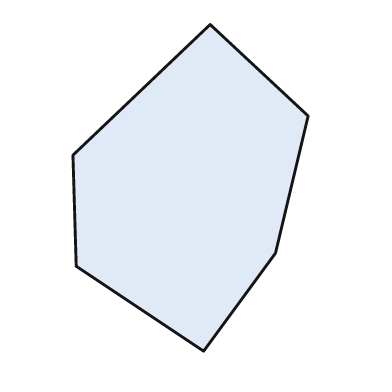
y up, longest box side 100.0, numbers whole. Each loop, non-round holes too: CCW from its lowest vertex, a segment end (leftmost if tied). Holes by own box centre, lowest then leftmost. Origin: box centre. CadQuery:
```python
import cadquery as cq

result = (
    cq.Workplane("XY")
    .moveTo(4.0, -50.0)
    .lineTo(26.0, -20.0)
    .lineTo(36.0, 22.0)
    .lineTo(6.0, 50.0)
    .lineTo(-36.0, 10.0)
    .lineTo(-35.0, -24.0)
    .close()
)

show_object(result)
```